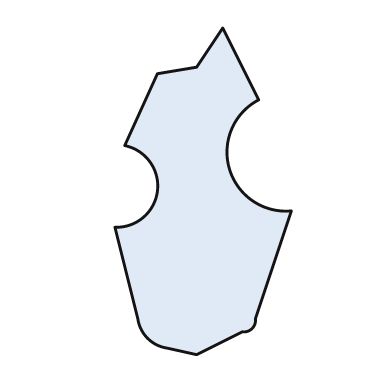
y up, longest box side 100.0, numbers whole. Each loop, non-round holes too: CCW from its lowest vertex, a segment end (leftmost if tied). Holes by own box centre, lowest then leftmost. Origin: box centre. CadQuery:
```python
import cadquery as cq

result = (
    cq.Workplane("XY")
    .moveTo(-2.0, -50.0)
    .lineTo(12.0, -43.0)
    .threePointArc((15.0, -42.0), (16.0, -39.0))
    .lineTo(27.0, -6.0)
    .threePointArc((8.0, 7.0), (17.0, 28.0))
    .lineTo(6.0, 50.0)
    .lineTo(-2.0, 38.0)
    .lineTo(-14.0, 36.0)
    .lineTo(-24.0, 14.0)
    .threePointArc((-14.0, 0.0), (-27.0, -11.0))
    .lineTo(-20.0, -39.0)
    .threePointArc((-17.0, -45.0), (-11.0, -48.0))
    .close()
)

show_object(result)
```